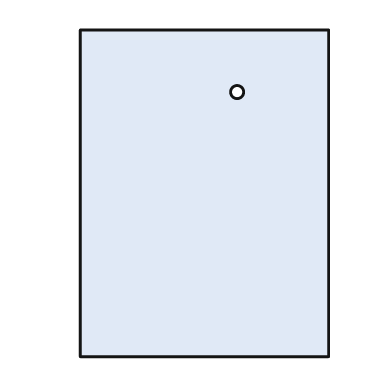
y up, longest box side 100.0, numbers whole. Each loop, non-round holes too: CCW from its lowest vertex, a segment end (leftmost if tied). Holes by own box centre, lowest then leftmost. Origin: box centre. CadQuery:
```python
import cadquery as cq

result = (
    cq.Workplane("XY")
    .moveTo(-38.0, -50.0)
    .lineTo(38.0, -50.0)
    .lineTo(38.0, 50.0)
    .lineTo(-38.0, 50.0)
    .close()
    .moveTo(10.0, 31.0)
    .circle(2.0)
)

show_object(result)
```